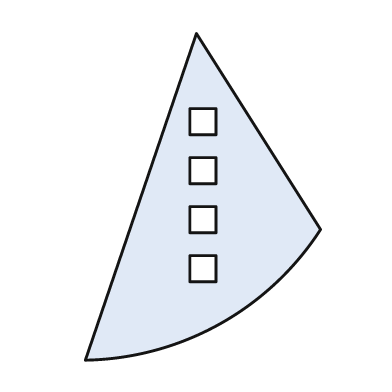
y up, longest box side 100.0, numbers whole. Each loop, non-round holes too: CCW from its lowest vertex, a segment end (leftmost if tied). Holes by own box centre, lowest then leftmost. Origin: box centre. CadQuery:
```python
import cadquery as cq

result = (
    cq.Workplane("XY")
    .moveTo(-36.0, -50.0)
    .threePointArc((5.0, -39.0), (36.0, -10.0))
    .lineTo(-2.0, 50.0)
    .close()
    .moveTo(-4.0, -26.0)
    .lineTo(4.0, -26.0)
    .lineTo(4.0, -18.0)
    .lineTo(-4.0, -18.0)
    .close()
    .moveTo(-4.0, -11.0)
    .lineTo(4.0, -11.0)
    .lineTo(4.0, -3.0)
    .lineTo(-4.0, -3.0)
    .close()
    .moveTo(-4.0, 4.0)
    .lineTo(4.0, 4.0)
    .lineTo(4.0, 12.0)
    .lineTo(-4.0, 12.0)
    .close()
    .moveTo(-4.0, 19.0)
    .lineTo(4.0, 19.0)
    .lineTo(4.0, 27.0)
    .lineTo(-4.0, 27.0)
    .close()
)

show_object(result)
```